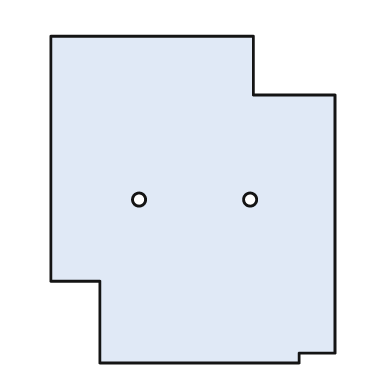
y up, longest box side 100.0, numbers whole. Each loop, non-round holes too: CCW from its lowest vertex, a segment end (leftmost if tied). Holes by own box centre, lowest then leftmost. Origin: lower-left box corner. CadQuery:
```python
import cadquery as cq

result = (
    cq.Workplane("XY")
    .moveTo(15.0, 0.0)
    .lineTo(76.0, 0.0)
    .lineTo(76.0, 3.0)
    .lineTo(87.0, 3.0)
    .lineTo(87.0, 82.0)
    .lineTo(62.0, 82.0)
    .lineTo(62.0, 100.0)
    .lineTo(0.0, 100.0)
    .lineTo(0.0, 25.0)
    .lineTo(15.0, 25.0)
    .close()
    .moveTo(27.0, 50.0)
    .circle(2.0)
    .moveTo(61.0, 50.0)
    .circle(2.0)
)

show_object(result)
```